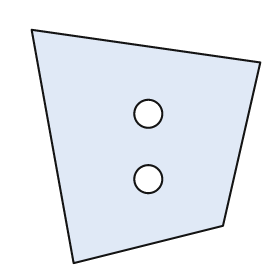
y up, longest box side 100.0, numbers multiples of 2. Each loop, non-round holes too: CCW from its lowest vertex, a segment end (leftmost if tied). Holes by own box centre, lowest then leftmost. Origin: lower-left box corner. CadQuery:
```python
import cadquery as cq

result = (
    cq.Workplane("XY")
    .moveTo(18.0, 0.0)
    .lineTo(82.0, 16.0)
    .lineTo(98.0, 86.0)
    .lineTo(0.0, 100.0)
    .close()
    .moveTo(50.0, 36.0)
    .circle(6.0)
    .moveTo(50.0, 64.0)
    .circle(6.0)
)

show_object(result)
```